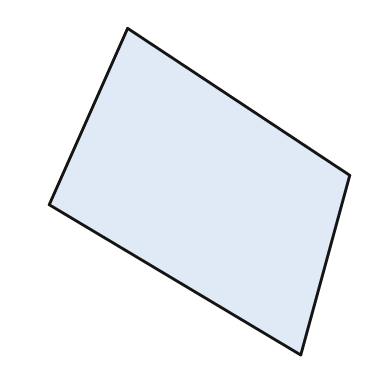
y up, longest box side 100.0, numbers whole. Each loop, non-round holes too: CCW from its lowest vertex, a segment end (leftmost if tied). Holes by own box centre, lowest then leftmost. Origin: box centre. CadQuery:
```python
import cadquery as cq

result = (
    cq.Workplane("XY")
    .moveTo(31.0, -50.0)
    .lineTo(46.0, 5.0)
    .lineTo(-22.0, 50.0)
    .lineTo(-46.0, -4.0)
    .close()
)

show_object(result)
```